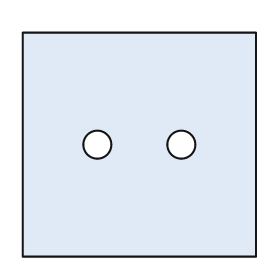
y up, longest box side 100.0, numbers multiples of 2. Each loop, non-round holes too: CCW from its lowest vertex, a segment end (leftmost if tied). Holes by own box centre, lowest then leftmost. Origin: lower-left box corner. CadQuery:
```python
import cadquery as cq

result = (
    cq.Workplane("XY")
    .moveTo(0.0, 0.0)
    .lineTo(100.0, 0.0)
    .lineTo(100.0, 96.0)
    .lineTo(0.0, 96.0)
    .close()
    .moveTo(32.0, 48.0)
    .circle(6.0)
    .moveTo(68.0, 48.0)
    .circle(6.0)
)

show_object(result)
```